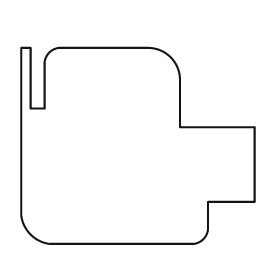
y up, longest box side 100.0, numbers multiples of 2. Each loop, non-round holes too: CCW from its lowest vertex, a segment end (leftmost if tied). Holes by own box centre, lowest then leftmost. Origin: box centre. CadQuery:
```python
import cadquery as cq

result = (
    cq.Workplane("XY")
    .moveTo(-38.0, -42.0)
    .lineTo(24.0, -42.0)
    .threePointArc((28.0, -40.0), (30.0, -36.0))
    .lineTo(30.0, -24.0)
    .lineTo(50.0, -24.0)
    .lineTo(50.0, 8.0)
    .lineTo(18.0, 8.0)
    .lineTo(18.0, 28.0)
    .threePointArc((14.0, 38.0), (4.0, 42.0))
    .lineTo(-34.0, 42.0)
    .threePointArc((-38.0, 40.0), (-40.0, 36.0))
    .lineTo(-40.0, 16.0)
    .lineTo(-46.0, 16.0)
    .lineTo(-46.0, 42.0)
    .lineTo(-50.0, 42.0)
    .lineTo(-50.0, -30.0)
    .threePointArc((-46.0, -38.0), (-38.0, -42.0))
    .close()
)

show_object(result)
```